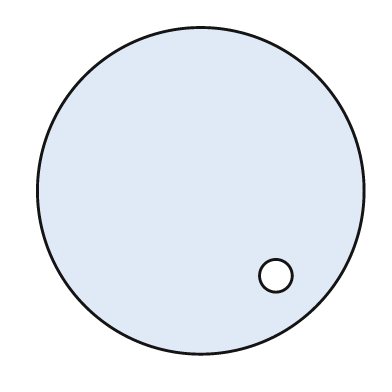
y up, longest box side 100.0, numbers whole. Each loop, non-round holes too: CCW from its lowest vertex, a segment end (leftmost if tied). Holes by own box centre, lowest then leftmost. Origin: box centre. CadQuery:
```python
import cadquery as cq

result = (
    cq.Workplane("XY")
    .moveTo(0.0, 0.0)
    .circle(50.0)
    .moveTo(23.0, -26.0)
    .circle(5.0)
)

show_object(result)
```